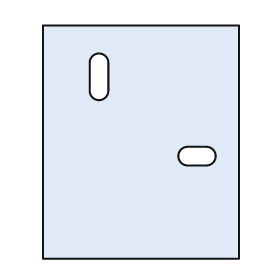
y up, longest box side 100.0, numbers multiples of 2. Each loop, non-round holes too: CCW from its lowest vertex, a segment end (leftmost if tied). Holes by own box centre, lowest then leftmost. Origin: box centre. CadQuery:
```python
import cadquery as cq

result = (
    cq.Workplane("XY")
    .moveTo(-42.0, -50.0)
    .lineTo(42.0, -50.0)
    .lineTo(42.0, 50.0)
    .lineTo(-42.0, 50.0)
    .close()
    .moveTo(20.0, -10.0)
    .lineTo(28.0, -10.0)
    .threePointArc((32.0, -6.0), (28.0, -2.0))
    .lineTo(20.0, -2.0)
    .threePointArc((16.0, -6.0), (20.0, -10.0))
    .close()
    .moveTo(-22.0, 22.0)
    .threePointArc((-18.0, 18.0), (-14.0, 22.0))
    .lineTo(-14.0, 34.0)
    .threePointArc((-18.0, 38.0), (-22.0, 34.0))
    .close()
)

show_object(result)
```